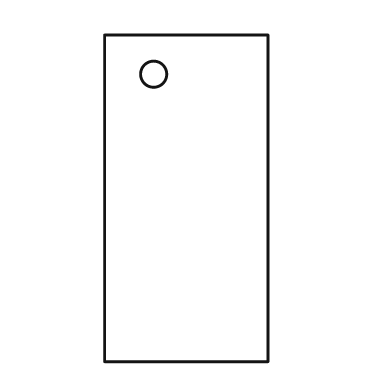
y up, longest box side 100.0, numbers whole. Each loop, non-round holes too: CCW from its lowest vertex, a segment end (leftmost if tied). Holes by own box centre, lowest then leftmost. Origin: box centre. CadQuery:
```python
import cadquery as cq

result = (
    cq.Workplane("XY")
    .moveTo(-25.0, -50.0)
    .lineTo(25.0, -50.0)
    .lineTo(25.0, 50.0)
    .lineTo(-25.0, 50.0)
    .close()
    .moveTo(-10.0, 38.0)
    .circle(4.0)
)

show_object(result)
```